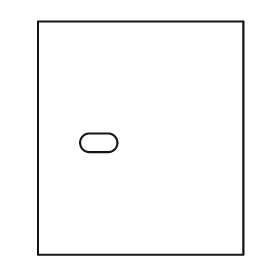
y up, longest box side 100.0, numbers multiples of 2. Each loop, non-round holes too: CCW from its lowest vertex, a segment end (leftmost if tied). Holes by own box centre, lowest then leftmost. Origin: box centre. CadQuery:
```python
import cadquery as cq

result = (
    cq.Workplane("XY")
    .moveTo(-44.0, -50.0)
    .lineTo(44.0, -50.0)
    .lineTo(44.0, 50.0)
    .lineTo(-44.0, 50.0)
    .close()
    .moveTo(-22.0, -6.0)
    .lineTo(-14.0, -6.0)
    .threePointArc((-10.0, -2.0), (-14.0, 2.0))
    .lineTo(-22.0, 2.0)
    .threePointArc((-26.0, -2.0), (-22.0, -6.0))
    .close()
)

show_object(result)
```